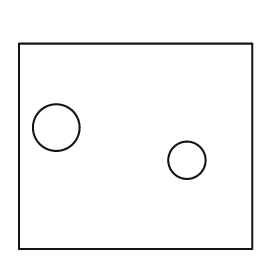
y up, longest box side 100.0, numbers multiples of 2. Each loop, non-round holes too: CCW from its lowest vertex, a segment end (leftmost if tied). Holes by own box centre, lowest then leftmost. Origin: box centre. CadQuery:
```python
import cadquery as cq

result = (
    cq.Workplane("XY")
    .moveTo(-50.0, -44.0)
    .lineTo(50.0, -44.0)
    .lineTo(50.0, 44.0)
    .lineTo(-50.0, 44.0)
    .close()
    .moveTo(22.0, -6.0)
    .circle(8.0)
    .moveTo(-34.0, 8.0)
    .circle(10.0)
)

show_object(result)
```